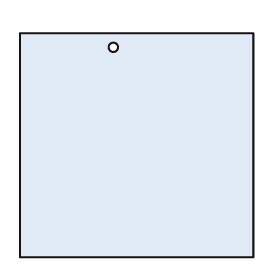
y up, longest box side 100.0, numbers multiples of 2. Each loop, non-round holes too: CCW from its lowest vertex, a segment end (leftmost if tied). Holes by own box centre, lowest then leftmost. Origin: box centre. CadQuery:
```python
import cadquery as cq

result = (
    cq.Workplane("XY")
    .moveTo(-50.0, -48.0)
    .lineTo(50.0, -48.0)
    .lineTo(50.0, 48.0)
    .lineTo(-50.0, 48.0)
    .close()
    .moveTo(-10.0, 42.0)
    .circle(2.0)
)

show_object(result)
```